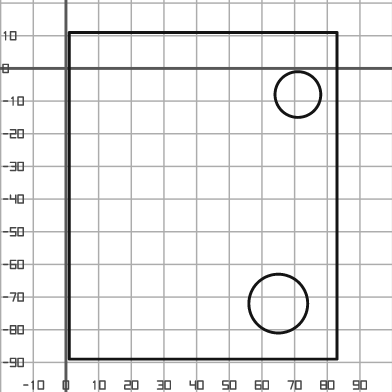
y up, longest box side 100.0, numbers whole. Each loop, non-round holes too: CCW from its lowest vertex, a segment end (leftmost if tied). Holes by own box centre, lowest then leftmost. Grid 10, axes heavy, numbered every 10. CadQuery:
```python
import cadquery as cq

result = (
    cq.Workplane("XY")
    .moveTo(1.0, -89.0)
    .lineTo(83.0, -89.0)
    .lineTo(83.0, 11.0)
    .lineTo(1.0, 11.0)
    .close()
    .moveTo(65.0, -72.0)
    .circle(9.0)
    .moveTo(71.0, -8.0)
    .circle(7.0)
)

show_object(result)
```